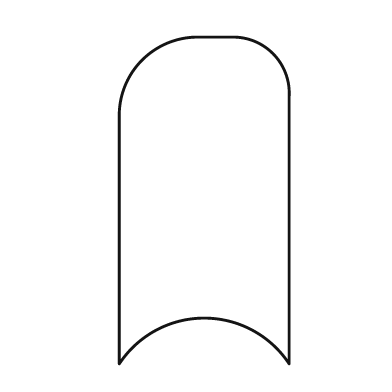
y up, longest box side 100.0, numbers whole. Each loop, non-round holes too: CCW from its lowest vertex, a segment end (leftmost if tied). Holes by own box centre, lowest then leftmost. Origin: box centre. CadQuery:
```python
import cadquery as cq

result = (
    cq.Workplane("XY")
    .moveTo(-26.0, -50.0)
    .threePointArc((0.0, -36.0), (26.0, -50.0))
    .lineTo(26.0, 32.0)
    .threePointArc((21.0, 45.0), (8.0, 50.0))
    .lineTo(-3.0, 50.0)
    .threePointArc((-19.0, 43.0), (-26.0, 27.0))
    .close()
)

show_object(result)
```